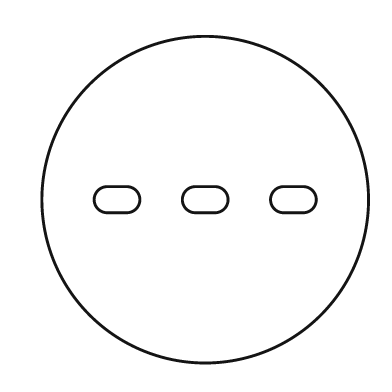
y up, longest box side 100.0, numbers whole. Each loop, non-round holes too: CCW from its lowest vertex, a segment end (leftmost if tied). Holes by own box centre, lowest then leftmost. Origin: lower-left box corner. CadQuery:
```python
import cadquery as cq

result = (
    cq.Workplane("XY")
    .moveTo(50.0, 50.0)
    .circle(50.0)
    .moveTo(20.0, 46.0)
    .lineTo(26.0, 46.0)
    .threePointArc((30.0, 50.0), (26.0, 54.0))
    .lineTo(20.0, 54.0)
    .threePointArc((16.0, 50.0), (20.0, 46.0))
    .close()
    .moveTo(47.0, 46.0)
    .lineTo(53.0, 46.0)
    .threePointArc((57.0, 50.0), (53.0, 54.0))
    .lineTo(47.0, 54.0)
    .threePointArc((43.0, 50.0), (47.0, 46.0))
    .close()
    .moveTo(74.0, 46.0)
    .lineTo(80.0, 46.0)
    .threePointArc((84.0, 50.0), (80.0, 54.0))
    .lineTo(74.0, 54.0)
    .threePointArc((70.0, 50.0), (74.0, 46.0))
    .close()
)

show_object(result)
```